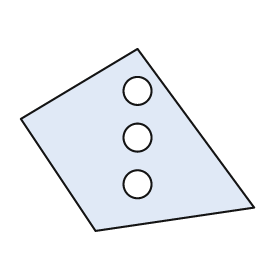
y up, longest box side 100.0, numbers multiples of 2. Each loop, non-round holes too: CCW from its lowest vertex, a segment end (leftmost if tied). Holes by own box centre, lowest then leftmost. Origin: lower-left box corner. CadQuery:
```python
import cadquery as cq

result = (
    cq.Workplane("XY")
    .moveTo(32.0, 0.0)
    .lineTo(100.0, 10.0)
    .lineTo(50.0, 78.0)
    .lineTo(0.0, 48.0)
    .close()
    .moveTo(50.0, 20.0)
    .circle(6.0)
    .moveTo(50.0, 40.0)
    .circle(6.0)
    .moveTo(50.0, 60.0)
    .circle(6.0)
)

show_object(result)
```